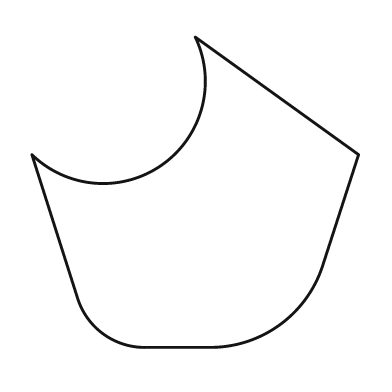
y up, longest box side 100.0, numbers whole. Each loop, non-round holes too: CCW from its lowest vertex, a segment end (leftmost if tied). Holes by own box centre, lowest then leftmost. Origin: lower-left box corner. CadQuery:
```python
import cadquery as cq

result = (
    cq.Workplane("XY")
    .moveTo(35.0, 0.0)
    .lineTo(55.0, 0.0)
    .threePointArc((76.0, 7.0), (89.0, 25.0))
    .lineTo(100.0, 59.0)
    .lineTo(50.0, 95.0)
    .threePointArc((40.0, 56.0), (0.0, 59.0))
    .lineTo(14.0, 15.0)
    .threePointArc((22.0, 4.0), (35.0, 0.0))
    .close()
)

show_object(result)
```